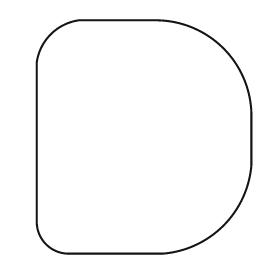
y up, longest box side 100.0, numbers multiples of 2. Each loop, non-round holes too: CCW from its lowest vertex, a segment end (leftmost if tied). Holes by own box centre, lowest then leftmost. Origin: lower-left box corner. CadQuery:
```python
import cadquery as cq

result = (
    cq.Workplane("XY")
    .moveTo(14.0, 0.0)
    .lineTo(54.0, 0.0)
    .threePointArc((80.0, 12.0), (92.0, 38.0))
    .lineTo(92.0, 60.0)
    .threePointArc((80.0, 88.0), (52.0, 100.0))
    .lineTo(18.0, 100.0)
    .threePointArc((6.0, 94.0), (0.0, 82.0))
    .lineTo(0.0, 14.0)
    .threePointArc((4.0, 4.0), (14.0, 0.0))
    .close()
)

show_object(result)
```